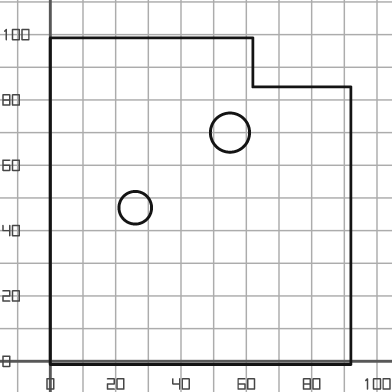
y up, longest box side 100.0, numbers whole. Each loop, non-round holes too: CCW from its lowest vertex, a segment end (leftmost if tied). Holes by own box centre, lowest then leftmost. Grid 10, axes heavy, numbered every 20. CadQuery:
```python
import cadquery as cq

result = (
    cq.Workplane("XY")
    .moveTo(0.0, -1.0)
    .lineTo(92.0, -1.0)
    .lineTo(92.0, 84.0)
    .lineTo(62.0, 84.0)
    .lineTo(62.0, 99.0)
    .lineTo(0.0, 99.0)
    .close()
    .moveTo(26.0, 47.0)
    .circle(5.0)
    .moveTo(55.0, 70.0)
    .circle(6.0)
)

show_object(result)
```